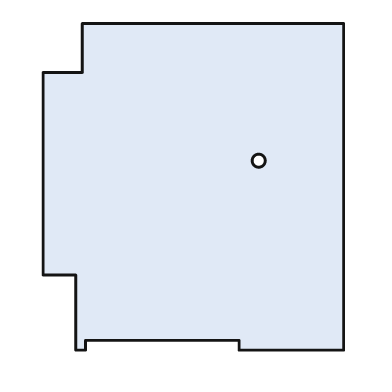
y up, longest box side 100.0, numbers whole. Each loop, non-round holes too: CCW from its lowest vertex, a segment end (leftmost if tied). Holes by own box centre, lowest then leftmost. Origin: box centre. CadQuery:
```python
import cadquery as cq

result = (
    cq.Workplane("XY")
    .moveTo(-36.0, -50.0)
    .lineTo(-33.0, -50.0)
    .lineTo(-33.0, -47.0)
    .lineTo(14.0, -47.0)
    .lineTo(14.0, -50.0)
    .lineTo(46.0, -50.0)
    .lineTo(46.0, 50.0)
    .lineTo(-34.0, 50.0)
    .lineTo(-34.0, 35.0)
    .lineTo(-46.0, 35.0)
    .lineTo(-46.0, -27.0)
    .lineTo(-36.0, -27.0)
    .close()
    .moveTo(20.0, 8.0)
    .circle(2.0)
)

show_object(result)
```